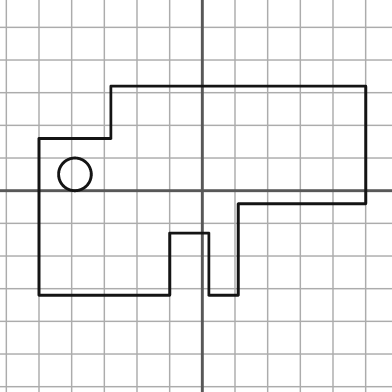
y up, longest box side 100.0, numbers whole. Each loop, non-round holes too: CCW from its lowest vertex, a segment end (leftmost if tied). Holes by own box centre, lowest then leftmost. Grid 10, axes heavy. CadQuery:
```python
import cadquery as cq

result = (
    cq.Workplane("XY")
    .moveTo(-50.0, -32.0)
    .lineTo(-10.0, -32.0)
    .lineTo(-10.0, -13.0)
    .lineTo(2.0, -13.0)
    .lineTo(2.0, -32.0)
    .lineTo(11.0, -32.0)
    .lineTo(11.0, -4.0)
    .lineTo(50.0, -4.0)
    .lineTo(50.0, 32.0)
    .lineTo(-28.0, 32.0)
    .lineTo(-28.0, 16.0)
    .lineTo(-50.0, 16.0)
    .close()
    .moveTo(-39.0, 5.0)
    .circle(5.0)
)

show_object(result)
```